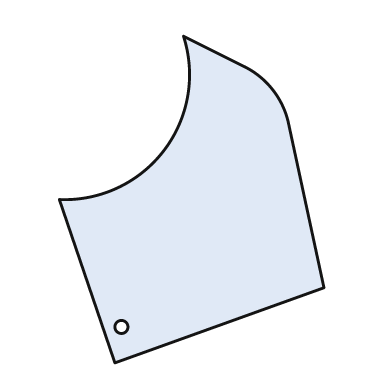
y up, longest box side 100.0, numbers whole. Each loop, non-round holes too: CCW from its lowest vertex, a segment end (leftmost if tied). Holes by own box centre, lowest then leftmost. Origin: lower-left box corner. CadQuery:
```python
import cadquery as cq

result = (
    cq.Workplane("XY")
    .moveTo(17.0, 0.0)
    .lineTo(81.0, 23.0)
    .lineTo(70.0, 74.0)
    .threePointArc((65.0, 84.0), (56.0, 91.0))
    .lineTo(38.0, 100.0)
    .threePointArc((32.0, 65.0), (0.0, 50.0))
    .close()
    .moveTo(19.0, 11.0)
    .circle(2.0)
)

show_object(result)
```